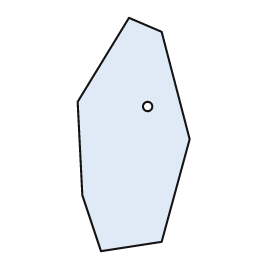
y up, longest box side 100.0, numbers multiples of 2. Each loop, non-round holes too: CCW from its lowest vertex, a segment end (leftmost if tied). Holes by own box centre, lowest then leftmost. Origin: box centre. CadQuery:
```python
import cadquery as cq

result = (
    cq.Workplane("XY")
    .moveTo(-14.0, -50.0)
    .lineTo(12.0, -46.0)
    .lineTo(24.0, -2.0)
    .lineTo(12.0, 44.0)
    .lineTo(-2.0, 50.0)
    .lineTo(-24.0, 14.0)
    .lineTo(-22.0, -26.0)
    .close()
    .moveTo(6.0, 12.0)
    .circle(2.0)
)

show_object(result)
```